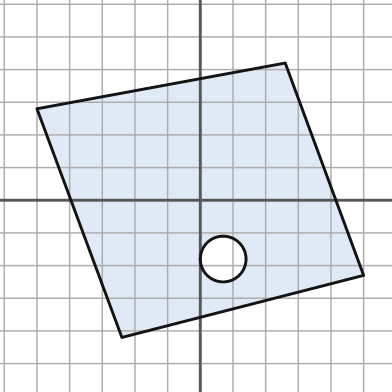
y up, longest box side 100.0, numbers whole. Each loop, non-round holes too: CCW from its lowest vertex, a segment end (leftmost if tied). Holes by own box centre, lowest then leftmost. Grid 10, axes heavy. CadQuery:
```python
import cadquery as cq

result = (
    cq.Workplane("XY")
    .moveTo(-24.0, -42.0)
    .lineTo(50.0, -23.0)
    .lineTo(26.0, 42.0)
    .lineTo(-50.0, 28.0)
    .close()
    .moveTo(7.0, -18.0)
    .circle(7.0)
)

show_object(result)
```